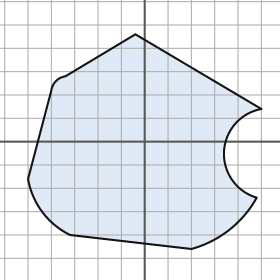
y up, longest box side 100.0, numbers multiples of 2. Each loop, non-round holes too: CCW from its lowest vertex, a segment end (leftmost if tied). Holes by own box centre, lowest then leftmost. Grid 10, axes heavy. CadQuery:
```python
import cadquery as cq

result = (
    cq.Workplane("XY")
    .moveTo(20.0, -46.0)
    .threePointArc((36.0, -38.0), (48.0, -24.0))
    .threePointArc((34.0, -4.0), (50.0, 14.0))
    .lineTo(-4.0, 46.0)
    .lineTo(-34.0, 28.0)
    .threePointArc((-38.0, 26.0), (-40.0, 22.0))
    .lineTo(-50.0, -16.0)
    .threePointArc((-44.0, -30.0), (-32.0, -40.0))
    .close()
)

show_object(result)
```